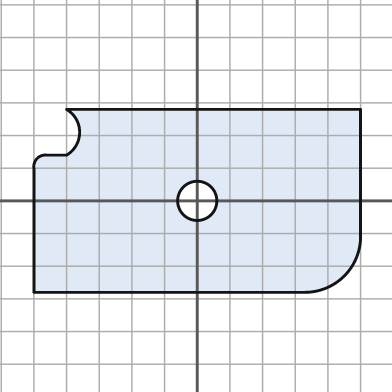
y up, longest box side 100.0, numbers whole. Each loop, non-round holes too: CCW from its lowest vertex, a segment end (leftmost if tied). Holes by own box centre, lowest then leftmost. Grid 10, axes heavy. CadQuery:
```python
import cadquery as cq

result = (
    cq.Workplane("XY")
    .moveTo(-50.0, -28.0)
    .lineTo(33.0, -28.0)
    .threePointArc((45.0, -23.0), (50.0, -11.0))
    .lineTo(50.0, 28.0)
    .lineTo(-40.0, 28.0)
    .threePointArc((-36.0, 21.0), (-40.0, 14.0))
    .lineTo(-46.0, 14.0)
    .threePointArc((-49.0, 13.0), (-50.0, 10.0))
    .close()
    .moveTo(0.0, 0.0)
    .circle(6.0)
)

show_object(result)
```